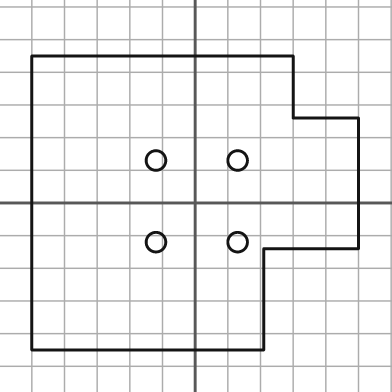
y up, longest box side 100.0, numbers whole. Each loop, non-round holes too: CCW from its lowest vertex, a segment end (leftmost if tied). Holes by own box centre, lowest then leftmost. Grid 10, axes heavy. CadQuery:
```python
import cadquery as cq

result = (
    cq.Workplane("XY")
    .moveTo(-50.0, -45.0)
    .lineTo(21.0, -45.0)
    .lineTo(21.0, -14.0)
    .lineTo(50.0, -14.0)
    .lineTo(50.0, 26.0)
    .lineTo(30.0, 26.0)
    .lineTo(30.0, 45.0)
    .lineTo(-50.0, 45.0)
    .close()
    .moveTo(-12.0, -12.0)
    .circle(3.0)
    .moveTo(13.0, -12.0)
    .circle(3.0)
    .moveTo(-12.0, 13.0)
    .circle(3.0)
    .moveTo(13.0, 13.0)
    .circle(3.0)
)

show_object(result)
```